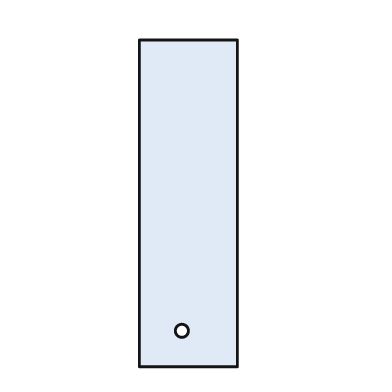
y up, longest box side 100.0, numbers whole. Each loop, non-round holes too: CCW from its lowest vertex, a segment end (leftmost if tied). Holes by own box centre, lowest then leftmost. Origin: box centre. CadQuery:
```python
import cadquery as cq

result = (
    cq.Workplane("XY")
    .moveTo(-15.0, -50.0)
    .lineTo(15.0, -50.0)
    .lineTo(15.0, 50.0)
    .lineTo(-15.0, 50.0)
    .close()
    .moveTo(-2.0, -39.0)
    .circle(2.0)
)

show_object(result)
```